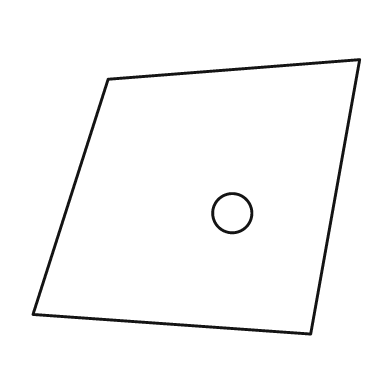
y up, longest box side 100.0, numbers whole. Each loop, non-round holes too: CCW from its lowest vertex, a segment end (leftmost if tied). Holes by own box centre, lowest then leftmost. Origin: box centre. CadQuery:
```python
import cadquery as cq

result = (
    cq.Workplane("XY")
    .moveTo(35.0, -42.0)
    .lineTo(50.0, 42.0)
    .lineTo(-27.0, 36.0)
    .lineTo(-50.0, -36.0)
    .close()
    .moveTo(11.0, -5.0)
    .circle(6.0)
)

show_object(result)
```